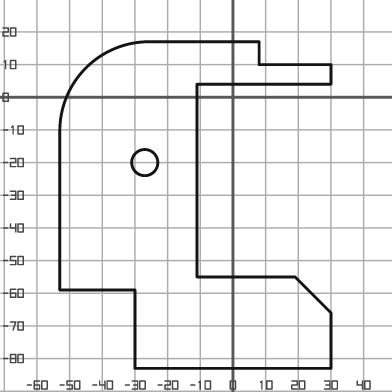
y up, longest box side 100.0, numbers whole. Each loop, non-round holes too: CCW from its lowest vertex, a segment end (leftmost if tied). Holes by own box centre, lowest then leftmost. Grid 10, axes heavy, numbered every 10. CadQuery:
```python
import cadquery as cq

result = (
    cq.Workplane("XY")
    .moveTo(-30.0, -83.0)
    .lineTo(30.0, -83.0)
    .lineTo(30.0, -66.0)
    .lineTo(19.0, -55.0)
    .lineTo(-11.0, -55.0)
    .lineTo(-11.0, 4.0)
    .lineTo(30.0, 4.0)
    .lineTo(30.0, 10.0)
    .lineTo(8.0, 10.0)
    .lineTo(8.0, 17.0)
    .lineTo(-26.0, 17.0)
    .threePointArc((-45.0, 9.0), (-53.0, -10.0))
    .lineTo(-53.0, -59.0)
    .lineTo(-30.0, -59.0)
    .close()
    .moveTo(-27.0, -20.0)
    .circle(4.0)
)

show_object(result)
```